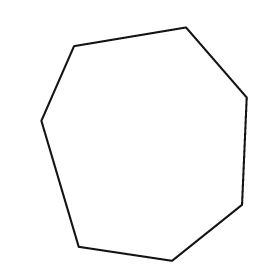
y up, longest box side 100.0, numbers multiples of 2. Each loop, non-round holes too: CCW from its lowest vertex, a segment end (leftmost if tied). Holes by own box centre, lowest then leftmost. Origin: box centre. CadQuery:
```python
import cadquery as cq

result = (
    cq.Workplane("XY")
    .moveTo(12.0, -50.0)
    .lineTo(42.0, -26.0)
    .lineTo(44.0, 20.0)
    .lineTo(18.0, 50.0)
    .lineTo(-30.0, 42.0)
    .lineTo(-44.0, 10.0)
    .lineTo(-28.0, -44.0)
    .close()
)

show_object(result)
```